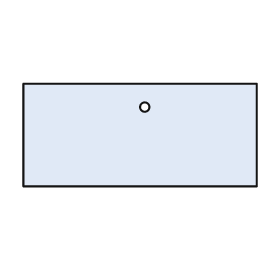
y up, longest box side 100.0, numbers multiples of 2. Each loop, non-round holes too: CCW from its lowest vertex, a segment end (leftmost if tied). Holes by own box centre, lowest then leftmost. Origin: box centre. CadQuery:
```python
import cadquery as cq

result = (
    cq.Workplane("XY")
    .moveTo(-50.0, -22.0)
    .lineTo(50.0, -22.0)
    .lineTo(50.0, 22.0)
    .lineTo(-50.0, 22.0)
    .close()
    .moveTo(2.0, 12.0)
    .circle(2.0)
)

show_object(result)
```